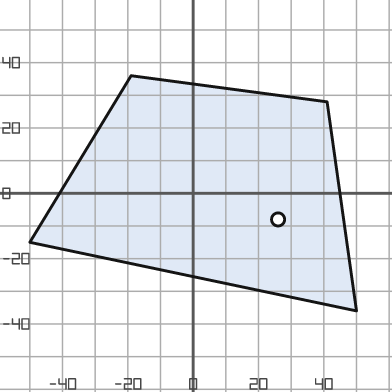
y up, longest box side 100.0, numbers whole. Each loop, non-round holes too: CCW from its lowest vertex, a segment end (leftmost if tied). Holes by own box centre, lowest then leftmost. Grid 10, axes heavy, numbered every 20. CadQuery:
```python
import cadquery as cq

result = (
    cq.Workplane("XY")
    .moveTo(50.0, -36.0)
    .lineTo(41.0, 28.0)
    .lineTo(-19.0, 36.0)
    .lineTo(-50.0, -15.0)
    .close()
    .moveTo(26.0, -8.0)
    .circle(2.0)
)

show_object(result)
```